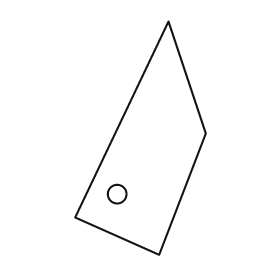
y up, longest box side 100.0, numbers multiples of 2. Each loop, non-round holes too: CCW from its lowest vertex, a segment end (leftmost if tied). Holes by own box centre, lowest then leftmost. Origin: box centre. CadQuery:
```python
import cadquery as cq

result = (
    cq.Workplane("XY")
    .moveTo(8.0, -50.0)
    .lineTo(28.0, 2.0)
    .lineTo(12.0, 50.0)
    .lineTo(-28.0, -34.0)
    .close()
    .moveTo(-10.0, -24.0)
    .circle(4.0)
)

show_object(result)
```